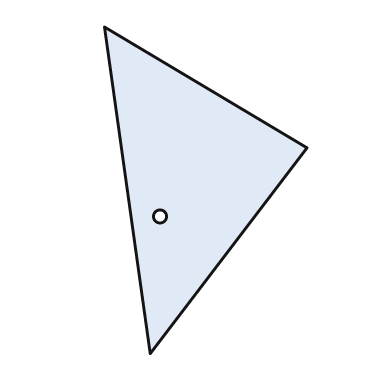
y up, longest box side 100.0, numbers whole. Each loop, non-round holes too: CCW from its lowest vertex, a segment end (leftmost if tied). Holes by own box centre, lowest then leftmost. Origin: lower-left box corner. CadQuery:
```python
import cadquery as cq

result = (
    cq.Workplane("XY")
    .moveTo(14.0, 0.0)
    .lineTo(62.0, 63.0)
    .lineTo(0.0, 100.0)
    .close()
    .moveTo(17.0, 42.0)
    .circle(2.0)
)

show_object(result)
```